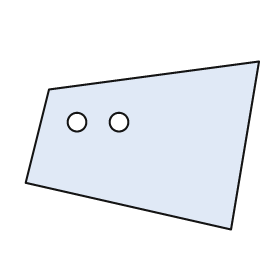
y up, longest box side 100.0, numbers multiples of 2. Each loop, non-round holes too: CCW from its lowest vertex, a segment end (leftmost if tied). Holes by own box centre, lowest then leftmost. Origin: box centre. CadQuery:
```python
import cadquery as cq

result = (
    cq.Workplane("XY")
    .moveTo(38.0, -36.0)
    .lineTo(50.0, 36.0)
    .lineTo(-40.0, 24.0)
    .lineTo(-50.0, -16.0)
    .close()
    .moveTo(-28.0, 10.0)
    .circle(4.0)
    .moveTo(-10.0, 10.0)
    .circle(4.0)
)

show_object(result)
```